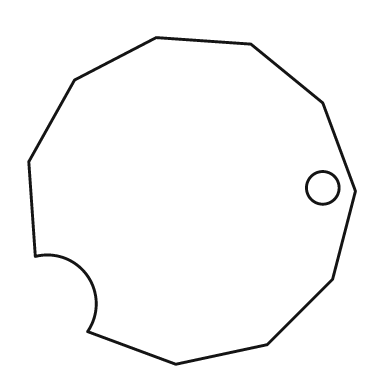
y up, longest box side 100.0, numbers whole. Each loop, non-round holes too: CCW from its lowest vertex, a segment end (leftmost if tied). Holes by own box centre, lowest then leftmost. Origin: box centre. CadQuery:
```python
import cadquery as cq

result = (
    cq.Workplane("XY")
    .moveTo(-5.0, -50.0)
    .lineTo(23.0, -44.0)
    .lineTo(43.0, -24.0)
    .lineTo(50.0, 3.0)
    .lineTo(40.0, 30.0)
    .lineTo(18.0, 48.0)
    .lineTo(-11.0, 50.0)
    .lineTo(-36.0, 37.0)
    .lineTo(-50.0, 12.0)
    .lineTo(-48.0, -17.0)
    .threePointArc((-32.0, -23.0), (-32.0, -40.0))
    .close()
    .moveTo(40.0, 4.0)
    .circle(5.0)
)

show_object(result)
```